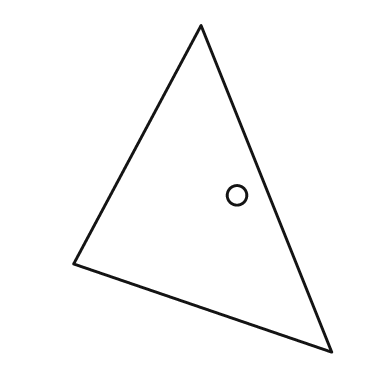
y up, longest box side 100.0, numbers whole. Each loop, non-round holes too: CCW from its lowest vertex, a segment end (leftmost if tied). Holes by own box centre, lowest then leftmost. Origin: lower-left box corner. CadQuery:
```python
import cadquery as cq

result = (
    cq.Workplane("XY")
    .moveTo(79.0, 0.0)
    .lineTo(39.0, 100.0)
    .lineTo(0.0, 27.0)
    .close()
    .moveTo(50.0, 48.0)
    .circle(3.0)
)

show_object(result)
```